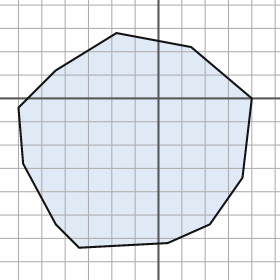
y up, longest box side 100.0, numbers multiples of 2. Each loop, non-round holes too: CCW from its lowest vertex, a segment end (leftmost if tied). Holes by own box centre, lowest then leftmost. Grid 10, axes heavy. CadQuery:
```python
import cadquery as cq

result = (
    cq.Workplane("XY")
    .moveTo(-34.0, -64.0)
    .lineTo(4.0, -62.0)
    .lineTo(22.0, -54.0)
    .lineTo(36.0, -34.0)
    .lineTo(40.0, 0.0)
    .lineTo(14.0, 22.0)
    .lineTo(-18.0, 28.0)
    .lineTo(-44.0, 12.0)
    .lineTo(-60.0, -4.0)
    .lineTo(-58.0, -28.0)
    .lineTo(-44.0, -54.0)
    .close()
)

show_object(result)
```